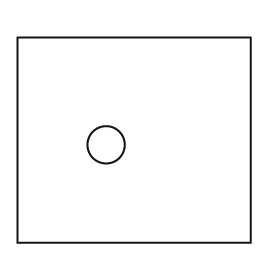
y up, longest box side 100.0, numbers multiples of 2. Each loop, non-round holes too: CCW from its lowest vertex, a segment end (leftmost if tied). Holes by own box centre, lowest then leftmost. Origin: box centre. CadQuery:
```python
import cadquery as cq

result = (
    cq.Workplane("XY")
    .moveTo(-50.0, -44.0)
    .lineTo(50.0, -44.0)
    .lineTo(50.0, 44.0)
    .lineTo(-50.0, 44.0)
    .close()
    .moveTo(-12.0, -2.0)
    .circle(8.0)
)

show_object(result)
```